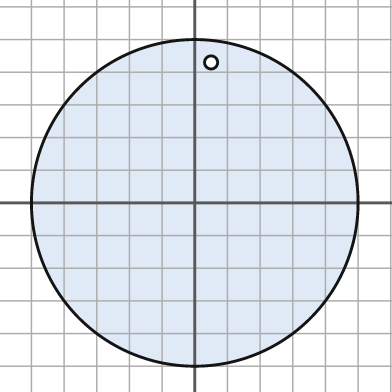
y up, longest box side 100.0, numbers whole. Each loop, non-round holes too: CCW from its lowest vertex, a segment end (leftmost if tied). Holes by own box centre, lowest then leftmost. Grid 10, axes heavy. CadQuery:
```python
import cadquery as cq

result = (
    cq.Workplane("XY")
    .moveTo(0.0, 0.0)
    .circle(50.0)
    .moveTo(5.0, 43.0)
    .circle(2.0)
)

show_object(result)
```